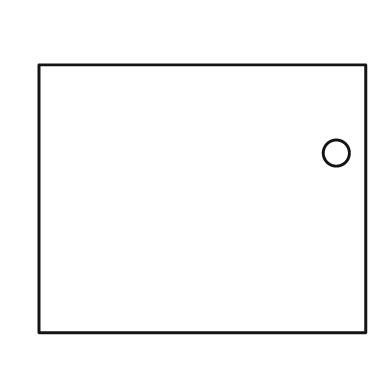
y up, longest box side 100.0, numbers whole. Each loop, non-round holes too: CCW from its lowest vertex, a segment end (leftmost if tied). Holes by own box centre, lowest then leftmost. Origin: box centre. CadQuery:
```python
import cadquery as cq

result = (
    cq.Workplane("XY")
    .moveTo(-50.0, -41.0)
    .lineTo(50.0, -41.0)
    .lineTo(50.0, 41.0)
    .lineTo(-50.0, 41.0)
    .close()
    .moveTo(41.0, 14.0)
    .circle(4.0)
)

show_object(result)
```